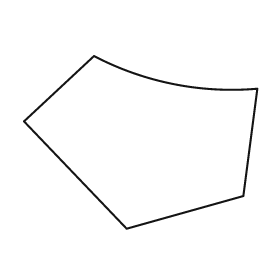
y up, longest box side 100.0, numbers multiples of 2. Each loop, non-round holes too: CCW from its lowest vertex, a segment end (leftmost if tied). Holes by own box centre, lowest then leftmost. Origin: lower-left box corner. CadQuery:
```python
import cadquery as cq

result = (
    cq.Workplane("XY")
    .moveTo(44.0, 0.0)
    .lineTo(94.0, 14.0)
    .lineTo(100.0, 60.0)
    .threePointArc((64.0, 62.0), (30.0, 74.0))
    .lineTo(0.0, 46.0)
    .close()
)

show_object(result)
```